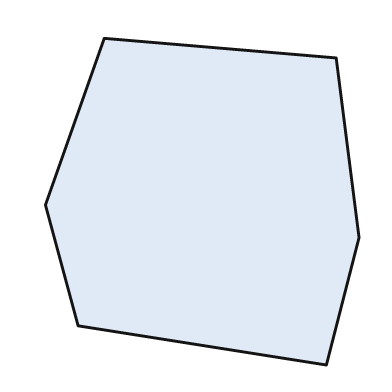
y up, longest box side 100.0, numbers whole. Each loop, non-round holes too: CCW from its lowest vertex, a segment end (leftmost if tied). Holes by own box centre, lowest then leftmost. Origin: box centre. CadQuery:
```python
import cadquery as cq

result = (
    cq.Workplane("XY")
    .moveTo(38.0, -50.0)
    .lineTo(48.0, -11.0)
    .lineTo(41.0, 44.0)
    .lineTo(-30.0, 50.0)
    .lineTo(-48.0, -1.0)
    .lineTo(-38.0, -38.0)
    .close()
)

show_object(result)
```